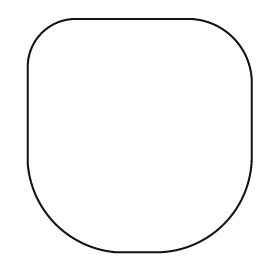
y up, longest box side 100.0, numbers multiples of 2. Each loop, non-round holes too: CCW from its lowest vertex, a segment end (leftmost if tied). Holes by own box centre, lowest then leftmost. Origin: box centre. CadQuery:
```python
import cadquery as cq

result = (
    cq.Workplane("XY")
    .moveTo(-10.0, -50.0)
    .lineTo(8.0, -50.0)
    .threePointArc((36.0, -38.0), (48.0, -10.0))
    .lineTo(48.0, 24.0)
    .threePointArc((40.0, 42.0), (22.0, 50.0))
    .lineTo(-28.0, 50.0)
    .threePointArc((-42.0, 44.0), (-48.0, 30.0))
    .lineTo(-48.0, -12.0)
    .threePointArc((-36.0, -38.0), (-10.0, -50.0))
    .close()
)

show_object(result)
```